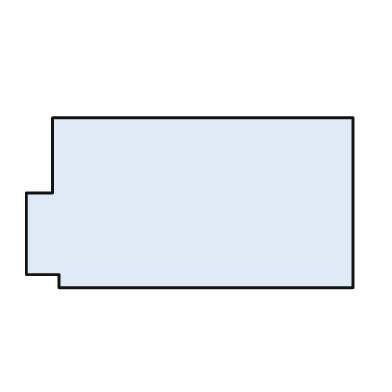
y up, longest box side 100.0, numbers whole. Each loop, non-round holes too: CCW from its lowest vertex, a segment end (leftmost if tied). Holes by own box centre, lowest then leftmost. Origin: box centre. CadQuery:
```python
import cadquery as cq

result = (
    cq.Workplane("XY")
    .moveTo(-40.0, -26.0)
    .lineTo(50.0, -26.0)
    .lineTo(50.0, 26.0)
    .lineTo(-42.0, 26.0)
    .lineTo(-42.0, 3.0)
    .lineTo(-50.0, 3.0)
    .lineTo(-50.0, -22.0)
    .lineTo(-40.0, -22.0)
    .close()
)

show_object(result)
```